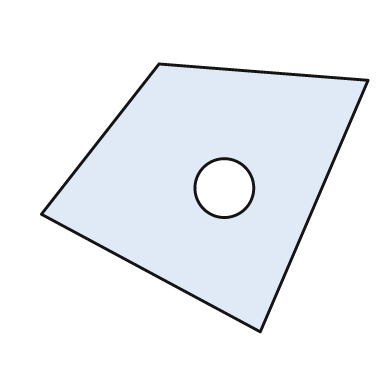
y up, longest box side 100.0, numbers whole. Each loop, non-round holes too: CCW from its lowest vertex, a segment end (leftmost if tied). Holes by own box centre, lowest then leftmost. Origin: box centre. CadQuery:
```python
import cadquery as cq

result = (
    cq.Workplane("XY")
    .moveTo(17.0, -41.0)
    .lineTo(50.0, 36.0)
    .lineTo(-14.0, 41.0)
    .lineTo(-50.0, -5.0)
    .close()
    .moveTo(6.0, 3.0)
    .circle(9.0)
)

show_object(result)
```